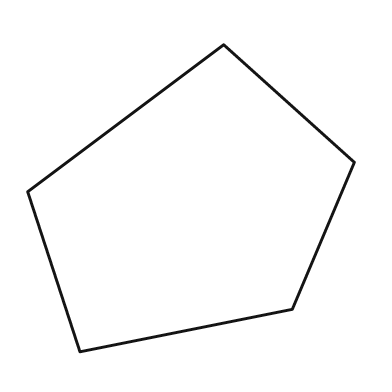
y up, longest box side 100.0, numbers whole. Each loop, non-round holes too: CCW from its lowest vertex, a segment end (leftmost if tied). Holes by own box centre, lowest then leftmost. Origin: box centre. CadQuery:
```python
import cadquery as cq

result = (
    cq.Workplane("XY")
    .moveTo(-34.0, -47.0)
    .lineTo(31.0, -34.0)
    .lineTo(50.0, 11.0)
    .lineTo(10.0, 47.0)
    .lineTo(-50.0, 2.0)
    .close()
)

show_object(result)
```